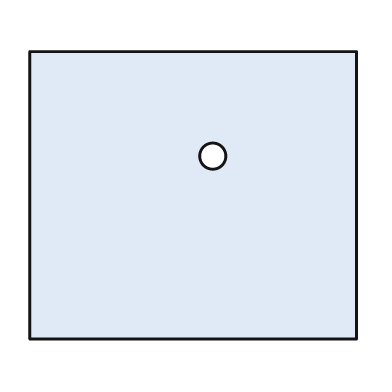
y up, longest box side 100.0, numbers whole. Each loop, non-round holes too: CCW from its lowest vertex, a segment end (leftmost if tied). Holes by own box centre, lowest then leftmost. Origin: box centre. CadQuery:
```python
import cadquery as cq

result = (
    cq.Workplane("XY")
    .moveTo(-50.0, -44.0)
    .lineTo(50.0, -44.0)
    .lineTo(50.0, 44.0)
    .lineTo(-50.0, 44.0)
    .close()
    .moveTo(6.0, 12.0)
    .circle(4.0)
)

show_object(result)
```